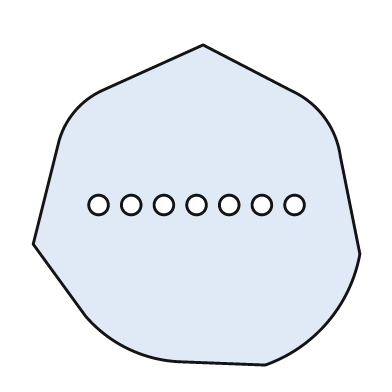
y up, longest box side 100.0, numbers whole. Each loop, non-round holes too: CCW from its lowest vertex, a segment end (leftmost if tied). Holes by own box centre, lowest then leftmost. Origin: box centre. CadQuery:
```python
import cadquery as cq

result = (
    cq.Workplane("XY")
    .moveTo(21.0, -49.0)
    .threePointArc((40.0, -36.0), (50.0, -15.0))
    .lineTo(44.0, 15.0)
    .threePointArc((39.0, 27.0), (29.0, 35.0))
    .lineTo(2.0, 49.0)
    .lineTo(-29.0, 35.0)
    .threePointArc((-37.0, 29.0), (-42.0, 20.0))
    .lineTo(-50.0, -12.0)
    .lineTo(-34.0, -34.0)
    .threePointArc((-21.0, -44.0), (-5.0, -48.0))
    .close()
    .moveTo(-30.0, 0.0)
    .circle(3.0)
    .moveTo(-20.0, 0.0)
    .circle(3.0)
    .moveTo(-10.0, 0.0)
    .circle(3.0)
    .moveTo(0.0, 0.0)
    .circle(3.0)
    .moveTo(10.0, 0.0)
    .circle(3.0)
    .moveTo(20.0, 0.0)
    .circle(3.0)
    .moveTo(30.0, 0.0)
    .circle(3.0)
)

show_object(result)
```